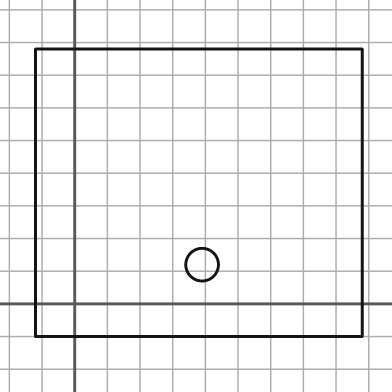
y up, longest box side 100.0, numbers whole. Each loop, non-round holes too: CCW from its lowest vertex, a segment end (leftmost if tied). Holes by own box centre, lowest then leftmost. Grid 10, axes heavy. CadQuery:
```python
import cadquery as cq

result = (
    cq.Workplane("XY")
    .moveTo(-12.0, -10.0)
    .lineTo(88.0, -10.0)
    .lineTo(88.0, 78.0)
    .lineTo(-12.0, 78.0)
    .close()
    .moveTo(39.0, 12.0)
    .circle(5.0)
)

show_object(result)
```